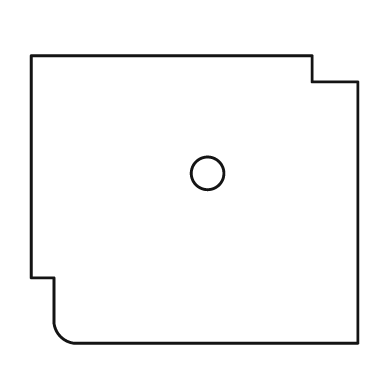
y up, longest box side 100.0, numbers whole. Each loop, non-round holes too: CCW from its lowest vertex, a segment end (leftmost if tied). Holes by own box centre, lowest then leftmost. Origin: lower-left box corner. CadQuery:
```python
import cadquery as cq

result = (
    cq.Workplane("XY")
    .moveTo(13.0, 0.0)
    .lineTo(100.0, 0.0)
    .lineTo(100.0, 80.0)
    .lineTo(86.0, 80.0)
    .lineTo(86.0, 88.0)
    .lineTo(0.0, 88.0)
    .lineTo(0.0, 20.0)
    .lineTo(7.0, 20.0)
    .lineTo(7.0, 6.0)
    .threePointArc((9.0, 2.0), (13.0, 0.0))
    .close()
    .moveTo(54.0, 52.0)
    .circle(5.0)
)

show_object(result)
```